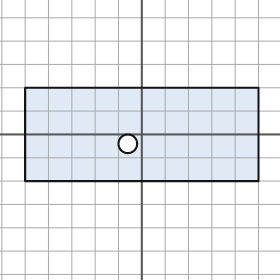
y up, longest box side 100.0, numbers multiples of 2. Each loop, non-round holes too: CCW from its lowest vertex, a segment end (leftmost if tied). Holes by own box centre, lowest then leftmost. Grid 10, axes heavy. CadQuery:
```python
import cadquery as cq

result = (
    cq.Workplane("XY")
    .moveTo(-50.0, -20.0)
    .lineTo(50.0, -20.0)
    .lineTo(50.0, 20.0)
    .lineTo(-50.0, 20.0)
    .close()
    .moveTo(-6.0, -4.0)
    .circle(4.0)
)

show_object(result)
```